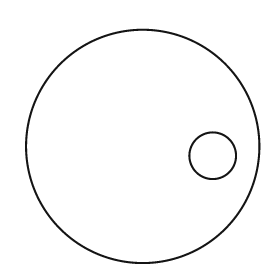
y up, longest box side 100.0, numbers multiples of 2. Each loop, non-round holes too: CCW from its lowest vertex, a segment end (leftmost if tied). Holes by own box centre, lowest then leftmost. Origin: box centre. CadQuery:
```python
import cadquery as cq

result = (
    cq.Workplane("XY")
    .moveTo(0.0, 0.0)
    .circle(50.0)
    .moveTo(30.0, -4.0)
    .circle(10.0)
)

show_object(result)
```